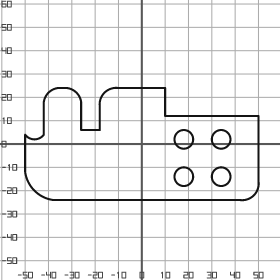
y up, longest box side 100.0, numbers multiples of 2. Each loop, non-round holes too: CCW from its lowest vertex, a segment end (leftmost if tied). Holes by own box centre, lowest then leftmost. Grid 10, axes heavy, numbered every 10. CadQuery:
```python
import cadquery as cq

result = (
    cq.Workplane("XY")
    .moveTo(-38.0, -24.0)
    .lineTo(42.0, -24.0)
    .threePointArc((48.0, -22.0), (50.0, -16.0))
    .lineTo(50.0, 12.0)
    .lineTo(10.0, 12.0)
    .lineTo(10.0, 24.0)
    .lineTo(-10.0, 24.0)
    .threePointArc((-16.0, 22.0), (-18.0, 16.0))
    .lineTo(-18.0, 6.0)
    .lineTo(-26.0, 6.0)
    .lineTo(-26.0, 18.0)
    .threePointArc((-28.0, 22.0), (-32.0, 24.0))
    .lineTo(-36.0, 24.0)
    .threePointArc((-40.0, 22.0), (-42.0, 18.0))
    .lineTo(-42.0, 4.0)
    .threePointArc((-46.0, 2.0), (-50.0, 4.0))
    .lineTo(-50.0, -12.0)
    .threePointArc((-46.0, -20.0), (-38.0, -24.0))
    .close()
    .moveTo(18.0, -14.0)
    .circle(4.0)
    .moveTo(34.0, -14.0)
    .circle(4.0)
    .moveTo(18.0, 2.0)
    .circle(4.0)
    .moveTo(34.0, 2.0)
    .circle(4.0)
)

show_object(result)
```